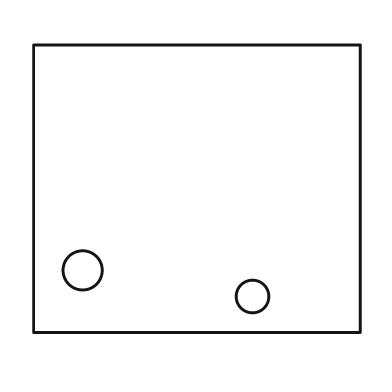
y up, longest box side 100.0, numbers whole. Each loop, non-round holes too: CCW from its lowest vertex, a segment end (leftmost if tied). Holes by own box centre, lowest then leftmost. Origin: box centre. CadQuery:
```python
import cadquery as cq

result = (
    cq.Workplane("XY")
    .moveTo(-50.0, -44.0)
    .lineTo(50.0, -44.0)
    .lineTo(50.0, 44.0)
    .lineTo(-50.0, 44.0)
    .close()
    .moveTo(17.0, -33.0)
    .circle(5.0)
    .moveTo(-35.0, -25.0)
    .circle(6.0)
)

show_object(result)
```